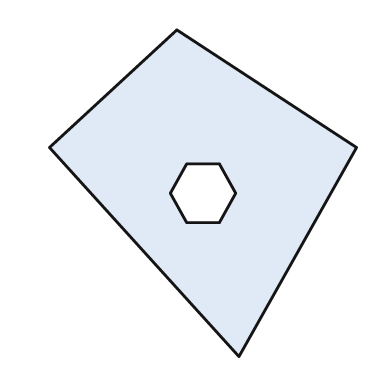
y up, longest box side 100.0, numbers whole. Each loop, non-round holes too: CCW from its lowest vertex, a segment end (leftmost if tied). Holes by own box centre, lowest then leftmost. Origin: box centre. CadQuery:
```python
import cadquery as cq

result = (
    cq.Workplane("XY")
    .moveTo(11.0, -50.0)
    .lineTo(47.0, 14.0)
    .lineTo(-8.0, 50.0)
    .lineTo(-47.0, 14.0)
    .close()
    .moveTo(-5.0, -9.0)
    .lineTo(5.0, -9.0)
    .lineTo(10.0, 0.0)
    .lineTo(5.0, 9.0)
    .lineTo(-5.0, 9.0)
    .lineTo(-10.0, 0.0)
    .close()
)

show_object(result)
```